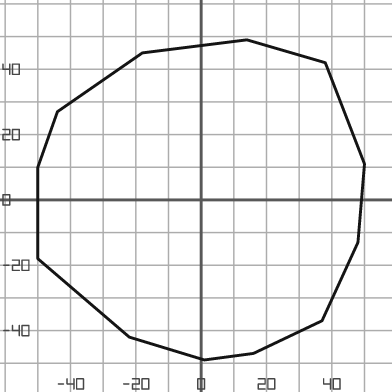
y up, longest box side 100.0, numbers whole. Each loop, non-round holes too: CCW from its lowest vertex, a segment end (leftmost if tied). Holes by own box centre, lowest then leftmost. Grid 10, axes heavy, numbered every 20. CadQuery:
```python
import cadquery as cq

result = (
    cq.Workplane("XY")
    .moveTo(1.0, -49.0)
    .lineTo(16.0, -47.0)
    .lineTo(37.0, -37.0)
    .lineTo(48.0, -13.0)
    .lineTo(50.0, 11.0)
    .lineTo(38.0, 42.0)
    .lineTo(14.0, 49.0)
    .lineTo(-18.0, 45.0)
    .lineTo(-44.0, 27.0)
    .lineTo(-50.0, 10.0)
    .lineTo(-50.0, -18.0)
    .lineTo(-22.0, -42.0)
    .close()
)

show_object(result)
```